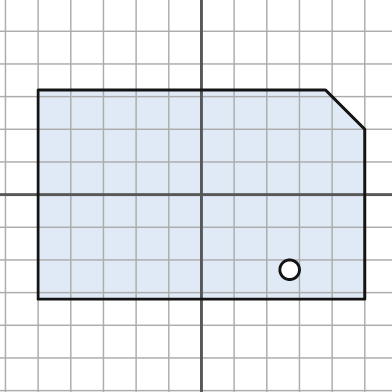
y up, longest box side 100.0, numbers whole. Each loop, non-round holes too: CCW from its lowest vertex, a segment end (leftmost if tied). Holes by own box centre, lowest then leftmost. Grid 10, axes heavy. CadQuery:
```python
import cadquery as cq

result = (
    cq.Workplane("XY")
    .moveTo(-50.0, -32.0)
    .lineTo(50.0, -32.0)
    .lineTo(50.0, 20.0)
    .lineTo(38.0, 32.0)
    .lineTo(-50.0, 32.0)
    .close()
    .moveTo(27.0, -23.0)
    .circle(3.0)
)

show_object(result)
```